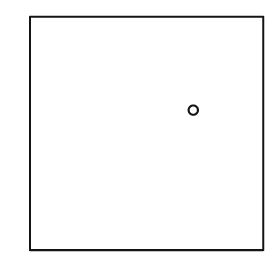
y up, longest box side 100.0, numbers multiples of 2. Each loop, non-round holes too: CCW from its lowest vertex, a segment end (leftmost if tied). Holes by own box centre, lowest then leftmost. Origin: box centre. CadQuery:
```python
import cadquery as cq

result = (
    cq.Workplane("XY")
    .moveTo(-50.0, -50.0)
    .lineTo(50.0, -50.0)
    .lineTo(50.0, 50.0)
    .lineTo(-50.0, 50.0)
    .close()
    .moveTo(20.0, 10.0)
    .circle(2.0)
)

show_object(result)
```